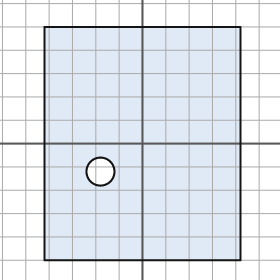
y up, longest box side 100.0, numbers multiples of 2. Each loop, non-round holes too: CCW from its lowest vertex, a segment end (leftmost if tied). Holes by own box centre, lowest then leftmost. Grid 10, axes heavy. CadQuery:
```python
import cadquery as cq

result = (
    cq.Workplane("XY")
    .moveTo(-42.0, -50.0)
    .lineTo(42.0, -50.0)
    .lineTo(42.0, 50.0)
    .lineTo(-42.0, 50.0)
    .close()
    .moveTo(-18.0, -12.0)
    .circle(6.0)
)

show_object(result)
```